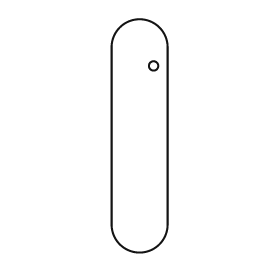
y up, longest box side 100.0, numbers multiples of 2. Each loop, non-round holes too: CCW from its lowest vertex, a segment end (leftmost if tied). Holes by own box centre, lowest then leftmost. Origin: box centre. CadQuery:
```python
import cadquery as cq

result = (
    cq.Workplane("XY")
    .moveTo(-12.0, -38.0)
    .threePointArc((0.0, -50.0), (12.0, -38.0))
    .lineTo(12.0, 38.0)
    .threePointArc((0.0, 50.0), (-12.0, 38.0))
    .close()
    .moveTo(6.0, 30.0)
    .circle(2.0)
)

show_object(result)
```